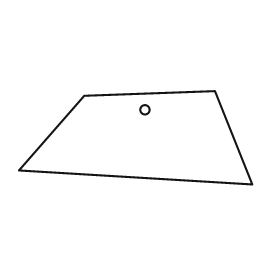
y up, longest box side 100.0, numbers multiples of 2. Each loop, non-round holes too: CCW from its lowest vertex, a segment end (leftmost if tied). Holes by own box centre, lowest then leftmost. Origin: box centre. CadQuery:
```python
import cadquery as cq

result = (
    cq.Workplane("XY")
    .moveTo(50.0, -20.0)
    .lineTo(34.0, 20.0)
    .lineTo(-22.0, 18.0)
    .lineTo(-50.0, -14.0)
    .close()
    .moveTo(4.0, 12.0)
    .circle(2.0)
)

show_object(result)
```